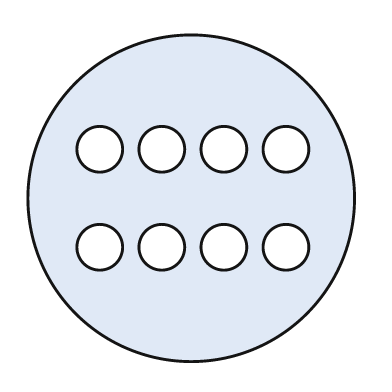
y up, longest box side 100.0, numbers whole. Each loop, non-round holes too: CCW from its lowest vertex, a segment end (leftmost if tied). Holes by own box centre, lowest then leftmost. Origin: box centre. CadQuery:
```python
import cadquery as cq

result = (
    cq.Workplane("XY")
    .moveTo(0.0, 0.0)
    .circle(50.0)
    .moveTo(-28.0, -15.0)
    .circle(7.0)
    .moveTo(-9.0, -15.0)
    .circle(7.0)
    .moveTo(10.0, -15.0)
    .circle(7.0)
    .moveTo(29.0, -15.0)
    .circle(7.0)
    .moveTo(-28.0, 15.0)
    .circle(7.0)
    .moveTo(-9.0, 15.0)
    .circle(7.0)
    .moveTo(10.0, 15.0)
    .circle(7.0)
    .moveTo(29.0, 15.0)
    .circle(7.0)
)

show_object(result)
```